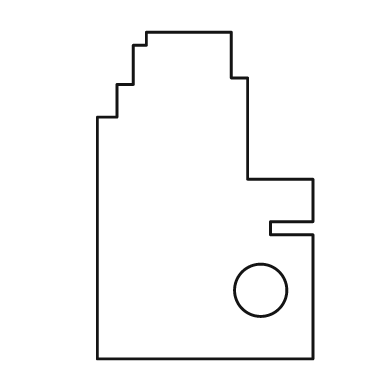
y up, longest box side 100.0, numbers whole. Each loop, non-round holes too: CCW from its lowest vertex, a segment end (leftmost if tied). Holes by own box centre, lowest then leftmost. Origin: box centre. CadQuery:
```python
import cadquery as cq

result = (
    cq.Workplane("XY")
    .moveTo(-33.0, -50.0)
    .lineTo(33.0, -50.0)
    .lineTo(33.0, -12.0)
    .lineTo(20.0, -12.0)
    .lineTo(20.0, -8.0)
    .lineTo(33.0, -8.0)
    .lineTo(33.0, 5.0)
    .lineTo(13.0, 5.0)
    .lineTo(13.0, 36.0)
    .lineTo(8.0, 36.0)
    .lineTo(8.0, 50.0)
    .lineTo(-18.0, 50.0)
    .lineTo(-18.0, 46.0)
    .lineTo(-22.0, 46.0)
    .lineTo(-22.0, 34.0)
    .lineTo(-27.0, 34.0)
    .lineTo(-27.0, 24.0)
    .lineTo(-33.0, 24.0)
    .close()
    .moveTo(17.0, -29.0)
    .circle(8.0)
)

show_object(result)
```